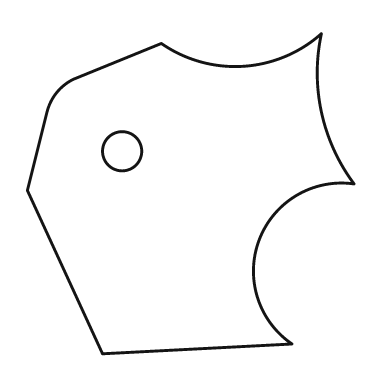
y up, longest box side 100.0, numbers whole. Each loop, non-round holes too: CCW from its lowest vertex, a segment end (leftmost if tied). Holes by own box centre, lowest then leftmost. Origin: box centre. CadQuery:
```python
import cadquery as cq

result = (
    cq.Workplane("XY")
    .moveTo(-27.0, -49.0)
    .lineTo(31.0, -46.0)
    .threePointArc((21.0, -14.0), (50.0, 3.0))
    .threePointArc((40.0, 25.0), (40.0, 49.0))
    .threePointArc((16.0, 39.0), (-9.0, 46.0))
    .lineTo(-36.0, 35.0)
    .threePointArc((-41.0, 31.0), (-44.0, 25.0))
    .lineTo(-50.0, 1.0)
    .close()
    .moveTo(-21.0, 13.0)
    .circle(6.0)
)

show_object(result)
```